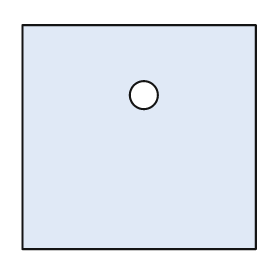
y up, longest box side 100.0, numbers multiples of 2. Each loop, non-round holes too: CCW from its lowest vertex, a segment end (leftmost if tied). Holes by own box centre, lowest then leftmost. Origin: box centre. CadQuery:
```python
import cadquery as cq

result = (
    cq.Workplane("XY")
    .moveTo(-50.0, -48.0)
    .lineTo(50.0, -48.0)
    .lineTo(50.0, 48.0)
    .lineTo(-50.0, 48.0)
    .close()
    .moveTo(2.0, 18.0)
    .circle(6.0)
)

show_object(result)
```